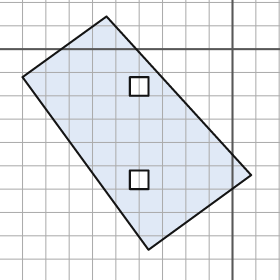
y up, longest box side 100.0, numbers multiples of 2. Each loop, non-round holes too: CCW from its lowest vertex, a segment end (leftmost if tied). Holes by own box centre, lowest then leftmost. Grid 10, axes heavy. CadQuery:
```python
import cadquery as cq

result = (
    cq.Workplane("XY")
    .moveTo(-36.0, -86.0)
    .lineTo(8.0, -54.0)
    .lineTo(-54.0, 14.0)
    .lineTo(-90.0, -12.0)
    .close()
    .moveTo(-44.0, -60.0)
    .lineTo(-36.0, -60.0)
    .lineTo(-36.0, -52.0)
    .lineTo(-44.0, -52.0)
    .close()
    .moveTo(-44.0, -20.0)
    .lineTo(-36.0, -20.0)
    .lineTo(-36.0, -12.0)
    .lineTo(-44.0, -12.0)
    .close()
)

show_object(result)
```